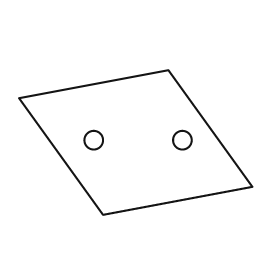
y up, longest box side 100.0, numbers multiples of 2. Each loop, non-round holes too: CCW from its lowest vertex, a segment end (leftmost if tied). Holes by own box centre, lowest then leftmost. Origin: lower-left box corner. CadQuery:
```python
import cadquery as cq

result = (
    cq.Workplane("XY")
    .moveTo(36.0, 0.0)
    .lineTo(100.0, 12.0)
    .lineTo(64.0, 62.0)
    .lineTo(0.0, 50.0)
    .close()
    .moveTo(32.0, 32.0)
    .circle(4.0)
    .moveTo(70.0, 32.0)
    .circle(4.0)
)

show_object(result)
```